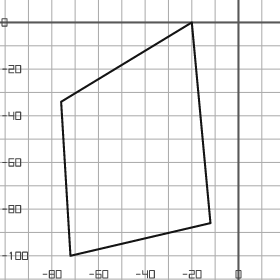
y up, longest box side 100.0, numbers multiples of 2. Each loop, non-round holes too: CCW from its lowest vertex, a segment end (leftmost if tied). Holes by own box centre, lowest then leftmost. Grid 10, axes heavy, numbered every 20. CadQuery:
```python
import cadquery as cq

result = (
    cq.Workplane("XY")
    .moveTo(-72.0, -100.0)
    .lineTo(-12.0, -86.0)
    .lineTo(-20.0, 0.0)
    .lineTo(-76.0, -34.0)
    .close()
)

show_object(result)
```